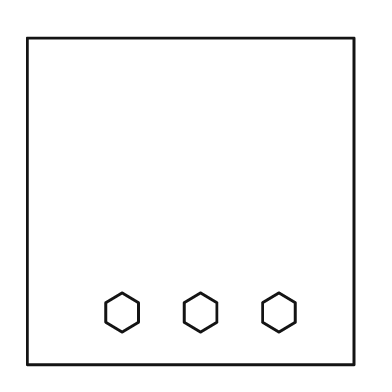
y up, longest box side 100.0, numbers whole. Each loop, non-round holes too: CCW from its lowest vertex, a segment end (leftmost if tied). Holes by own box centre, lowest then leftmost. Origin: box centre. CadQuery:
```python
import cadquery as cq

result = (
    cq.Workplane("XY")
    .moveTo(-50.0, -50.0)
    .lineTo(50.0, -50.0)
    .lineTo(50.0, 50.0)
    .lineTo(-50.0, 50.0)
    .close()
    .moveTo(-21.0, -40.0)
    .lineTo(-16.0, -37.0)
    .lineTo(-16.0, -31.0)
    .lineTo(-21.0, -28.0)
    .lineTo(-26.0, -31.0)
    .lineTo(-26.0, -37.0)
    .close()
    .moveTo(3.0, -40.0)
    .lineTo(8.0, -37.0)
    .lineTo(8.0, -31.0)
    .lineTo(3.0, -28.0)
    .lineTo(-2.0, -31.0)
    .lineTo(-2.0, -37.0)
    .close()
    .moveTo(27.0, -40.0)
    .lineTo(32.0, -37.0)
    .lineTo(32.0, -31.0)
    .lineTo(27.0, -28.0)
    .lineTo(22.0, -31.0)
    .lineTo(22.0, -37.0)
    .close()
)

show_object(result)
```